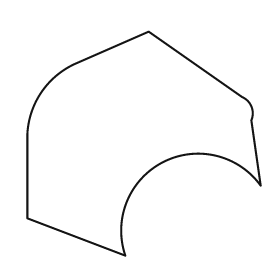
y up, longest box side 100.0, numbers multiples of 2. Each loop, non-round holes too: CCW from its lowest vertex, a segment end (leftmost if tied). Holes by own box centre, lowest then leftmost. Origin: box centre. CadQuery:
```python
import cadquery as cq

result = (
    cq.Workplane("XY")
    .moveTo(-8.0, -48.0)
    .threePointArc((8.0, -8.0), (50.0, -18.0))
    .lineTo(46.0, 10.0)
    .threePointArc((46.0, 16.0), (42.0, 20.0))
    .lineTo(2.0, 48.0)
    .lineTo(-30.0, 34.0)
    .threePointArc((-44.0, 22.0), (-50.0, 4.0))
    .lineTo(-50.0, -32.0)
    .close()
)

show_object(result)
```